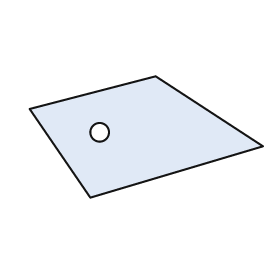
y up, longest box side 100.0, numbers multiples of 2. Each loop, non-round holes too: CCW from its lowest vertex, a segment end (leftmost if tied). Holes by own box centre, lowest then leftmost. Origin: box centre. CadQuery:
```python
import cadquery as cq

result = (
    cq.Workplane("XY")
    .moveTo(-24.0, -26.0)
    .lineTo(50.0, -4.0)
    .lineTo(4.0, 26.0)
    .lineTo(-50.0, 12.0)
    .close()
    .moveTo(-20.0, 2.0)
    .circle(4.0)
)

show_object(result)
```